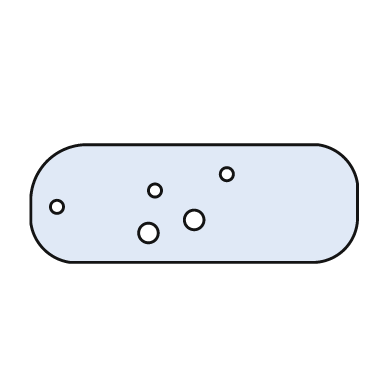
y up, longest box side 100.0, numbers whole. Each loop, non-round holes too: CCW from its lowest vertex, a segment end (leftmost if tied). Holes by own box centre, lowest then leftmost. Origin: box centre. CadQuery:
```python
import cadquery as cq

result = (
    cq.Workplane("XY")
    .moveTo(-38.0, -18.0)
    .lineTo(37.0, -18.0)
    .threePointArc((46.0, -14.0), (50.0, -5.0))
    .lineTo(50.0, 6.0)
    .threePointArc((46.0, 14.0), (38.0, 18.0))
    .lineTo(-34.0, 18.0)
    .threePointArc((-45.0, 13.0), (-50.0, 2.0))
    .lineTo(-50.0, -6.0)
    .threePointArc((-46.0, -14.0), (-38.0, -18.0))
    .close()
    .moveTo(-14.0, -9.0)
    .circle(3.0)
    .moveTo(0.0, -5.0)
    .circle(3.0)
    .moveTo(-42.0, -1.0)
    .circle(2.0)
    .moveTo(-12.0, 4.0)
    .circle(2.0)
    .moveTo(10.0, 9.0)
    .circle(2.0)
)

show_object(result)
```